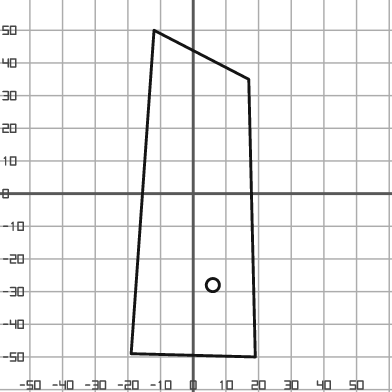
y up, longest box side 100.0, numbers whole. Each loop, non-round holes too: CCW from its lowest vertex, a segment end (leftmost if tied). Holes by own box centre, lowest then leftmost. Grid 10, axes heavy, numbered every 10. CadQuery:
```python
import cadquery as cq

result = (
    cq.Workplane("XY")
    .moveTo(19.0, -50.0)
    .lineTo(17.0, 35.0)
    .lineTo(-12.0, 50.0)
    .lineTo(-19.0, -49.0)
    .close()
    .moveTo(6.0, -28.0)
    .circle(2.0)
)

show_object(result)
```